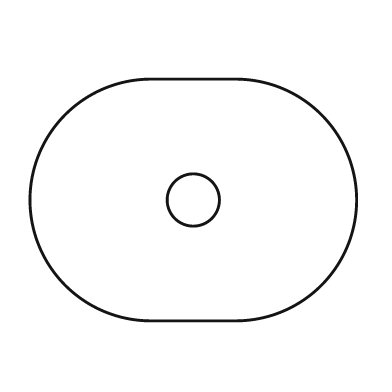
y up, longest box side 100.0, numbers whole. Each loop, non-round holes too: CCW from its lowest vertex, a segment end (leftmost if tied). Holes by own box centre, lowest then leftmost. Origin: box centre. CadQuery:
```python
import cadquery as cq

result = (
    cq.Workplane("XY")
    .moveTo(-13.0, -37.0)
    .lineTo(13.0, -37.0)
    .threePointArc((50.0, 0.0), (13.0, 37.0))
    .lineTo(-13.0, 37.0)
    .threePointArc((-50.0, 0.0), (-13.0, -37.0))
    .close()
    .moveTo(0.0, 0.0)
    .circle(8.0)
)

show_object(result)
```